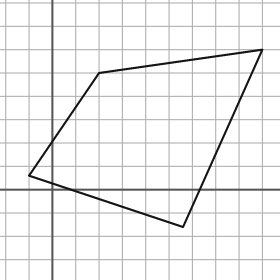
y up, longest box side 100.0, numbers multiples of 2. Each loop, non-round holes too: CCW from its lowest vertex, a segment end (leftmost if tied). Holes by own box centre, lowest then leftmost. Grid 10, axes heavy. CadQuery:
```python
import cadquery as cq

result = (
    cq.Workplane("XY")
    .moveTo(56.0, -16.0)
    .lineTo(90.0, 60.0)
    .lineTo(20.0, 50.0)
    .lineTo(-10.0, 6.0)
    .close()
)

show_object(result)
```